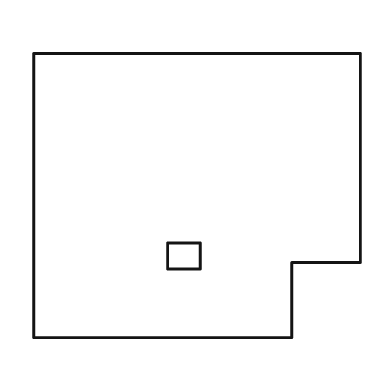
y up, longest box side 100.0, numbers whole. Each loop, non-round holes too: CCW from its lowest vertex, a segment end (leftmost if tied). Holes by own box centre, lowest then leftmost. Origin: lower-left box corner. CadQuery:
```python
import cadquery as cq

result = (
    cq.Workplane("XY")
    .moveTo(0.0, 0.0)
    .lineTo(79.0, 0.0)
    .lineTo(79.0, 23.0)
    .lineTo(100.0, 23.0)
    .lineTo(100.0, 87.0)
    .lineTo(0.0, 87.0)
    .close()
    .moveTo(41.0, 21.0)
    .lineTo(51.0, 21.0)
    .lineTo(51.0, 29.0)
    .lineTo(41.0, 29.0)
    .close()
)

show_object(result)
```